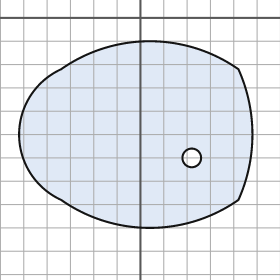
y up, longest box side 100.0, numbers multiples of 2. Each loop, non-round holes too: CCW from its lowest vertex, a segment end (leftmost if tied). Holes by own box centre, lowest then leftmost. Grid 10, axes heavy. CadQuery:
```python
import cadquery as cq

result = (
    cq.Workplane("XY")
    .moveTo(-34.0, -78.0)
    .threePointArc((4.0, -90.0), (42.0, -78.0))
    .threePointArc((48.0, -50.0), (42.0, -22.0))
    .threePointArc((4.0, -10.0), (-34.0, -22.0))
    .threePointArc((-52.0, -50.0), (-34.0, -78.0))
    .close()
    .moveTo(22.0, -60.0)
    .circle(4.0)
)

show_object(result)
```